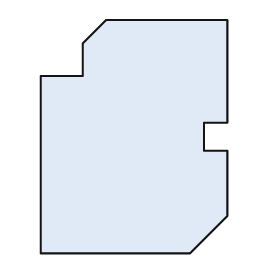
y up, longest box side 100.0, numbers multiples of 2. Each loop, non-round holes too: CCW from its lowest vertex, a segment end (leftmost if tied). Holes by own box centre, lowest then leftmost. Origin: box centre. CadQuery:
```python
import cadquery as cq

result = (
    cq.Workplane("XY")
    .moveTo(-40.0, -50.0)
    .lineTo(24.0, -50.0)
    .lineTo(40.0, -34.0)
    .lineTo(40.0, -6.0)
    .lineTo(30.0, -6.0)
    .lineTo(30.0, 6.0)
    .lineTo(40.0, 6.0)
    .lineTo(40.0, 50.0)
    .lineTo(-12.0, 50.0)
    .lineTo(-22.0, 40.0)
    .lineTo(-22.0, 26.0)
    .lineTo(-40.0, 26.0)
    .close()
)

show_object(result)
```